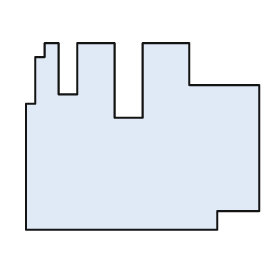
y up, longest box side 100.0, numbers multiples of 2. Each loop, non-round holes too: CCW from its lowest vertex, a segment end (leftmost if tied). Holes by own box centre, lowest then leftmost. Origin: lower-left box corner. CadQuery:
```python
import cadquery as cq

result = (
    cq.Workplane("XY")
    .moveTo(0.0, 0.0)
    .lineTo(82.0, 0.0)
    .lineTo(82.0, 8.0)
    .lineTo(100.0, 8.0)
    .lineTo(100.0, 62.0)
    .lineTo(70.0, 62.0)
    .lineTo(70.0, 80.0)
    .lineTo(50.0, 80.0)
    .lineTo(50.0, 48.0)
    .lineTo(38.0, 48.0)
    .lineTo(38.0, 80.0)
    .lineTo(22.0, 80.0)
    .lineTo(22.0, 58.0)
    .lineTo(14.0, 58.0)
    .lineTo(14.0, 80.0)
    .lineTo(8.0, 80.0)
    .lineTo(8.0, 74.0)
    .lineTo(4.0, 74.0)
    .lineTo(4.0, 54.0)
    .lineTo(0.0, 54.0)
    .close()
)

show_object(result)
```